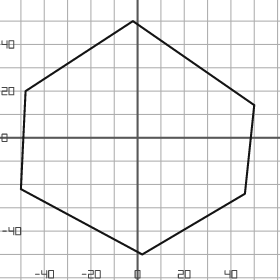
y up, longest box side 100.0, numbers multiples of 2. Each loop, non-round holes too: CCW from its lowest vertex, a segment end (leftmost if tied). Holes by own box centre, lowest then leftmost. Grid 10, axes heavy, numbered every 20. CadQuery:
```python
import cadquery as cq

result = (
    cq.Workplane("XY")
    .moveTo(2.0, -50.0)
    .lineTo(46.0, -24.0)
    .lineTo(50.0, 14.0)
    .lineTo(-2.0, 50.0)
    .lineTo(-48.0, 20.0)
    .lineTo(-50.0, -22.0)
    .close()
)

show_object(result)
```